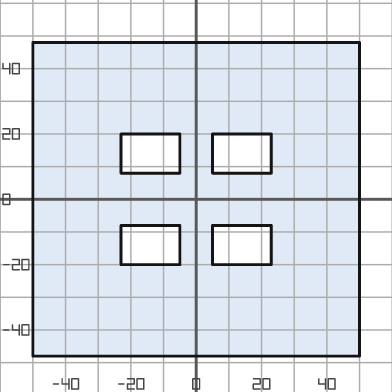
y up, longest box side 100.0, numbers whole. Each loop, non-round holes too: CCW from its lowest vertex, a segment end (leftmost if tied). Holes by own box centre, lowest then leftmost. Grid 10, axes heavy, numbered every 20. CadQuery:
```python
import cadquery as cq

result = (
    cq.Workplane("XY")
    .moveTo(-50.0, -48.0)
    .lineTo(50.0, -48.0)
    .lineTo(50.0, 48.0)
    .lineTo(-50.0, 48.0)
    .close()
    .moveTo(-23.0, -20.0)
    .lineTo(-5.0, -20.0)
    .lineTo(-5.0, -8.0)
    .lineTo(-23.0, -8.0)
    .close()
    .moveTo(5.0, -20.0)
    .lineTo(23.0, -20.0)
    .lineTo(23.0, -8.0)
    .lineTo(5.0, -8.0)
    .close()
    .moveTo(-23.0, 8.0)
    .lineTo(-5.0, 8.0)
    .lineTo(-5.0, 20.0)
    .lineTo(-23.0, 20.0)
    .close()
    .moveTo(5.0, 8.0)
    .lineTo(23.0, 8.0)
    .lineTo(23.0, 20.0)
    .lineTo(5.0, 20.0)
    .close()
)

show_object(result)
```